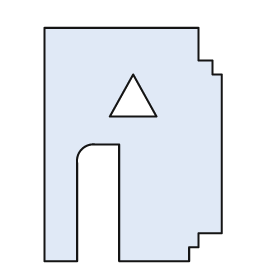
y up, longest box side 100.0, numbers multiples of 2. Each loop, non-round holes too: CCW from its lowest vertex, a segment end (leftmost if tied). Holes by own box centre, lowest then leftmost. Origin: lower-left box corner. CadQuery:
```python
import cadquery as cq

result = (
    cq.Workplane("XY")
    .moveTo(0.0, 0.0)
    .lineTo(14.0, 0.0)
    .lineTo(14.0, 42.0)
    .threePointArc((16.0, 48.0), (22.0, 50.0))
    .lineTo(32.0, 50.0)
    .lineTo(32.0, 0.0)
    .lineTo(62.0, 0.0)
    .lineTo(62.0, 6.0)
    .lineTo(66.0, 6.0)
    .lineTo(66.0, 12.0)
    .lineTo(76.0, 12.0)
    .lineTo(76.0, 80.0)
    .lineTo(72.0, 80.0)
    .lineTo(72.0, 86.0)
    .lineTo(66.0, 86.0)
    .lineTo(66.0, 100.0)
    .lineTo(0.0, 100.0)
    .close()
    .moveTo(28.0, 62.0)
    .lineTo(48.0, 62.0)
    .lineTo(38.0, 80.0)
    .close()
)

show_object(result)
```